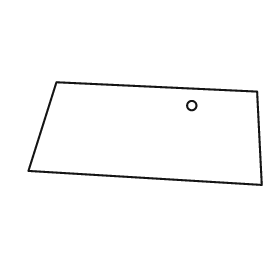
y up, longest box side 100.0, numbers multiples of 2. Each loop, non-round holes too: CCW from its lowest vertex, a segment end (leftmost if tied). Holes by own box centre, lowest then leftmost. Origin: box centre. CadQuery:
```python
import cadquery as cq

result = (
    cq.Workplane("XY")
    .moveTo(50.0, -22.0)
    .lineTo(48.0, 18.0)
    .lineTo(-38.0, 22.0)
    .lineTo(-50.0, -16.0)
    .close()
    .moveTo(20.0, 12.0)
    .circle(2.0)
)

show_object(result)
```